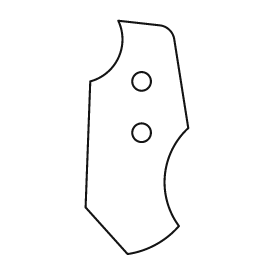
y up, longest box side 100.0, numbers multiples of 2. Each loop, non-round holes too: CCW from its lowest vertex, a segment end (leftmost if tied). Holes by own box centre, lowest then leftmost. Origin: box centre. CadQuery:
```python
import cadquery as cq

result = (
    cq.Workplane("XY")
    .moveTo(-4.0, -50.0)
    .threePointArc((8.0, -46.0), (18.0, -38.0))
    .threePointArc((12.0, -16.0), (22.0, 4.0))
    .lineTo(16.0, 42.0)
    .threePointArc((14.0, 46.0), (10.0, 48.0))
    .lineTo(-8.0, 50.0)
    .threePointArc((-8.0, 34.0), (-20.0, 24.0))
    .lineTo(-22.0, -30.0)
    .close()
    .moveTo(2.0, 2.0)
    .circle(4.0)
    .moveTo(2.0, 24.0)
    .circle(4.0)
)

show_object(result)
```